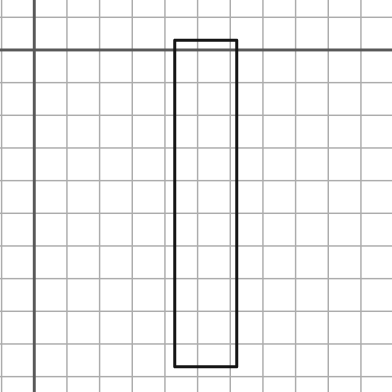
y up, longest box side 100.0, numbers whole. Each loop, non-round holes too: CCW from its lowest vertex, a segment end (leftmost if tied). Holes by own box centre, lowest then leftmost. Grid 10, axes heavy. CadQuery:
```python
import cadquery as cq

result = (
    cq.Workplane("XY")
    .moveTo(43.0, -97.0)
    .lineTo(62.0, -97.0)
    .lineTo(62.0, 3.0)
    .lineTo(43.0, 3.0)
    .close()
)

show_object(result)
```